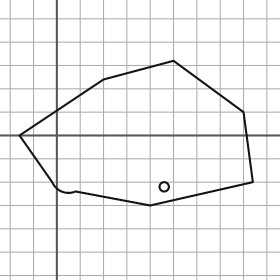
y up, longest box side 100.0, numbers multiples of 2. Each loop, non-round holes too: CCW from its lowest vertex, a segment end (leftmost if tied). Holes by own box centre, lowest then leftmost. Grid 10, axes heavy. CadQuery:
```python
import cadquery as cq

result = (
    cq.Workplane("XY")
    .moveTo(40.0, -30.0)
    .lineTo(84.0, -20.0)
    .lineTo(80.0, 10.0)
    .lineTo(50.0, 32.0)
    .lineTo(20.0, 24.0)
    .lineTo(-16.0, 0.0)
    .lineTo(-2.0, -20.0)
    .threePointArc((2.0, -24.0), (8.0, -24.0))
    .close()
    .moveTo(46.0, -22.0)
    .circle(2.0)
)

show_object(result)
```